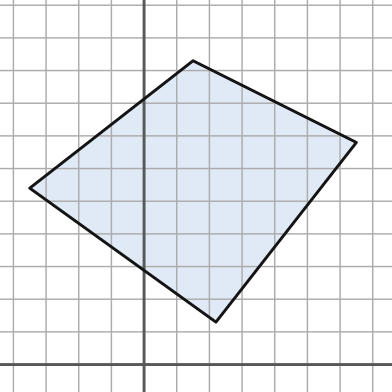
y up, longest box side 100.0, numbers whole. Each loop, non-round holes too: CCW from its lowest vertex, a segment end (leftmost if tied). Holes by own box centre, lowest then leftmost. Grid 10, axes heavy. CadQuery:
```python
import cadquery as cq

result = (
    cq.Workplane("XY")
    .moveTo(22.0, 13.0)
    .lineTo(65.0, 68.0)
    .lineTo(15.0, 93.0)
    .lineTo(-35.0, 54.0)
    .close()
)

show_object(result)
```